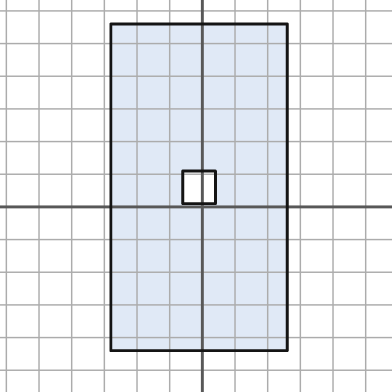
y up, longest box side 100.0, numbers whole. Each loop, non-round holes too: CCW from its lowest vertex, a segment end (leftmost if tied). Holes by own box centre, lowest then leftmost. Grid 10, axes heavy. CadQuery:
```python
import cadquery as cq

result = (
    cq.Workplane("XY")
    .moveTo(-28.0, -44.0)
    .lineTo(26.0, -44.0)
    .lineTo(26.0, 56.0)
    .lineTo(-28.0, 56.0)
    .close()
    .moveTo(-6.0, 1.0)
    .lineTo(4.0, 1.0)
    .lineTo(4.0, 11.0)
    .lineTo(-6.0, 11.0)
    .close()
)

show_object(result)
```